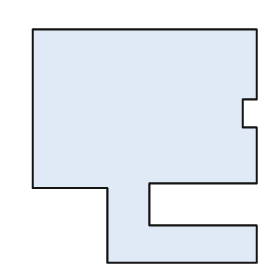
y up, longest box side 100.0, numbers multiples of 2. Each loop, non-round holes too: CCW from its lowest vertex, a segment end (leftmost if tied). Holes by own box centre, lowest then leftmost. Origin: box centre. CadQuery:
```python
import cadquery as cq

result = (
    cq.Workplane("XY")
    .moveTo(-16.0, -50.0)
    .lineTo(48.0, -50.0)
    .lineTo(48.0, -34.0)
    .lineTo(2.0, -34.0)
    .lineTo(2.0, -16.0)
    .lineTo(48.0, -16.0)
    .lineTo(48.0, 8.0)
    .lineTo(42.0, 8.0)
    .lineTo(42.0, 20.0)
    .lineTo(48.0, 20.0)
    .lineTo(48.0, 50.0)
    .lineTo(-48.0, 50.0)
    .lineTo(-48.0, -18.0)
    .lineTo(-16.0, -18.0)
    .close()
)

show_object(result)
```